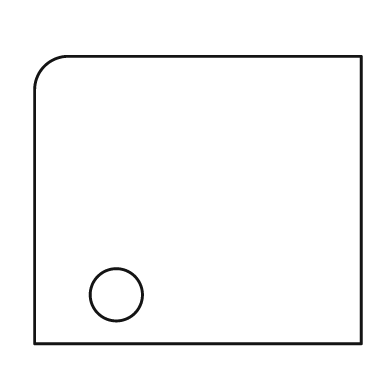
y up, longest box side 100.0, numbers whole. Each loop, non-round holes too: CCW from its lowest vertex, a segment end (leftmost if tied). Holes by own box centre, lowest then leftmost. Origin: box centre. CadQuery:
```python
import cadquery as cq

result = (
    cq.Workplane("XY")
    .moveTo(-50.0, -44.0)
    .lineTo(50.0, -44.0)
    .lineTo(50.0, 44.0)
    .lineTo(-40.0, 44.0)
    .threePointArc((-47.0, 41.0), (-50.0, 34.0))
    .close()
    .moveTo(-25.0, -29.0)
    .circle(8.0)
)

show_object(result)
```